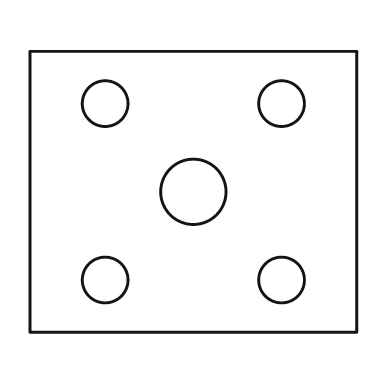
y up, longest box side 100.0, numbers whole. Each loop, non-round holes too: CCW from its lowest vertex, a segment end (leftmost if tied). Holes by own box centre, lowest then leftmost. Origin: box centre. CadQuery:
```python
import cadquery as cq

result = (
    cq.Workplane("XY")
    .moveTo(-50.0, -43.0)
    .lineTo(50.0, -43.0)
    .lineTo(50.0, 43.0)
    .lineTo(-50.0, 43.0)
    .close()
    .moveTo(-27.0, -27.0)
    .circle(7.0)
    .moveTo(27.0, -27.0)
    .circle(7.0)
    .moveTo(0.0, 0.0)
    .circle(10.0)
    .moveTo(-27.0, 27.0)
    .circle(7.0)
    .moveTo(27.0, 27.0)
    .circle(7.0)
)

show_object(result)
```